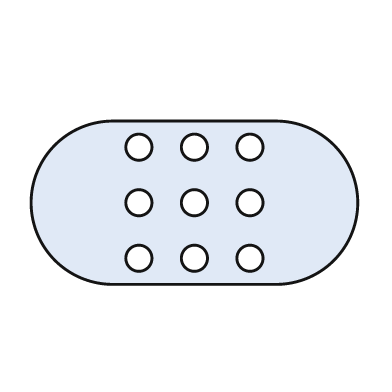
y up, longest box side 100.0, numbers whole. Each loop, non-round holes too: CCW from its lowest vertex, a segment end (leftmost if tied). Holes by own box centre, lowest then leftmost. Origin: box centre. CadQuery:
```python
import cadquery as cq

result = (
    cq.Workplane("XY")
    .moveTo(-25.0, -25.0)
    .lineTo(25.0, -25.0)
    .threePointArc((50.0, 0.0), (25.0, 25.0))
    .lineTo(-25.0, 25.0)
    .threePointArc((-50.0, 0.0), (-25.0, -25.0))
    .close()
    .moveTo(-17.0, -17.0)
    .circle(4.0)
    .moveTo(0.0, -17.0)
    .circle(4.0)
    .moveTo(17.0, -17.0)
    .circle(4.0)
    .moveTo(-17.0, 0.0)
    .circle(4.0)
    .moveTo(0.0, 0.0)
    .circle(4.0)
    .moveTo(17.0, 0.0)
    .circle(4.0)
    .moveTo(-17.0, 17.0)
    .circle(4.0)
    .moveTo(0.0, 17.0)
    .circle(4.0)
    .moveTo(17.0, 17.0)
    .circle(4.0)
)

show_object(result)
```